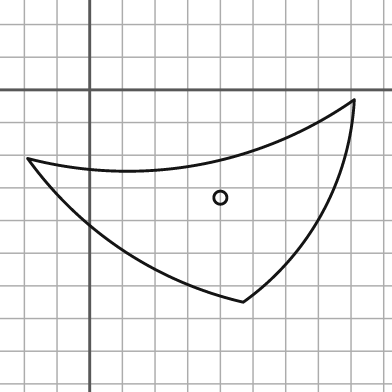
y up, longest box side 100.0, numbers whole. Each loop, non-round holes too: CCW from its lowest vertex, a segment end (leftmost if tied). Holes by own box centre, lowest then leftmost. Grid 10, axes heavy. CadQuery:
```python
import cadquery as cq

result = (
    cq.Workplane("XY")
    .moveTo(47.0, -65.0)
    .threePointArc((71.0, -38.0), (81.0, -3.0))
    .threePointArc((33.0, -23.0), (-19.0, -21.0))
    .threePointArc((10.0, -49.0), (47.0, -65.0))
    .close()
    .moveTo(40.0, -33.0)
    .circle(2.0)
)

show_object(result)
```